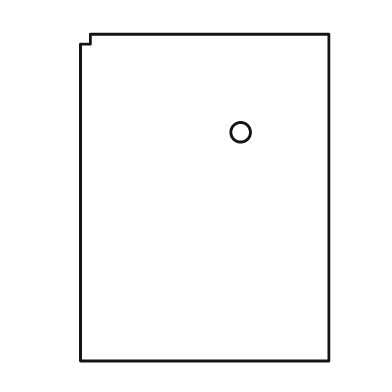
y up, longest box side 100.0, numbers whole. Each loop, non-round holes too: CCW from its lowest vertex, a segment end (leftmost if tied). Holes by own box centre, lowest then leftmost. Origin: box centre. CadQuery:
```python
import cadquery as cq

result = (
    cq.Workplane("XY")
    .moveTo(-38.0, -50.0)
    .lineTo(38.0, -50.0)
    .lineTo(38.0, 50.0)
    .lineTo(-35.0, 50.0)
    .lineTo(-35.0, 47.0)
    .lineTo(-38.0, 47.0)
    .close()
    .moveTo(11.0, 20.0)
    .circle(3.0)
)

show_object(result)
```